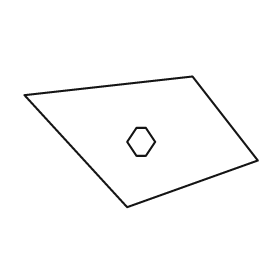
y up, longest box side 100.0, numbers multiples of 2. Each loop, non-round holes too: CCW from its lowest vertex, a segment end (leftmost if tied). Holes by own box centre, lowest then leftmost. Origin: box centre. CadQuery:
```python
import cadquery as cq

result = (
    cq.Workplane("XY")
    .moveTo(-6.0, -28.0)
    .lineTo(50.0, -8.0)
    .lineTo(22.0, 28.0)
    .lineTo(-50.0, 20.0)
    .close()
    .moveTo(-2.0, -6.0)
    .lineTo(2.0, -6.0)
    .lineTo(6.0, 0.0)
    .lineTo(2.0, 6.0)
    .lineTo(-2.0, 6.0)
    .lineTo(-6.0, 0.0)
    .close()
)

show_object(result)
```